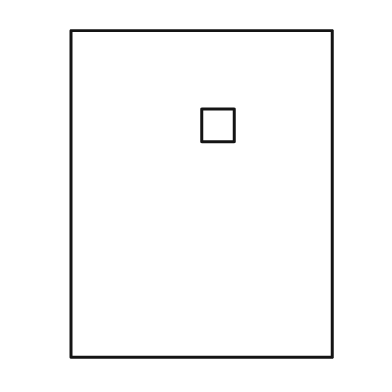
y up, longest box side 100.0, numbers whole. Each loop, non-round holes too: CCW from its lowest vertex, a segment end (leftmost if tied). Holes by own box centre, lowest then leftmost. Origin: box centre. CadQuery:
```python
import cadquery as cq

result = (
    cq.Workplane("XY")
    .moveTo(-40.0, -50.0)
    .lineTo(40.0, -50.0)
    .lineTo(40.0, 50.0)
    .lineTo(-40.0, 50.0)
    .close()
    .moveTo(0.0, 16.0)
    .lineTo(10.0, 16.0)
    .lineTo(10.0, 26.0)
    .lineTo(0.0, 26.0)
    .close()
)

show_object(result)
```